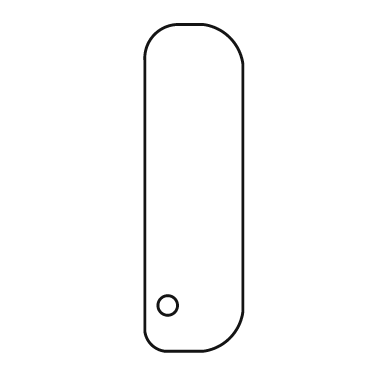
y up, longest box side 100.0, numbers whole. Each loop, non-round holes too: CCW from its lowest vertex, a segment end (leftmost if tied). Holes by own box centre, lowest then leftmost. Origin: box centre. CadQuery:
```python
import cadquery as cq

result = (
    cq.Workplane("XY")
    .moveTo(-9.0, -50.0)
    .lineTo(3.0, -50.0)
    .threePointArc((11.0, -46.0), (15.0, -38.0))
    .lineTo(15.0, 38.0)
    .threePointArc((11.0, 46.0), (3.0, 50.0))
    .lineTo(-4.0, 50.0)
    .threePointArc((-12.0, 47.0), (-15.0, 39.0))
    .lineTo(-15.0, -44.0)
    .threePointArc((-13.0, -48.0), (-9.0, -50.0))
    .close()
    .moveTo(-8.0, -36.0)
    .circle(3.0)
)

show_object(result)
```